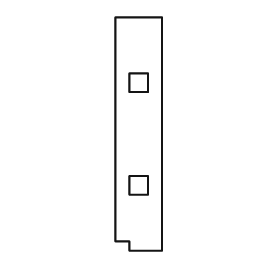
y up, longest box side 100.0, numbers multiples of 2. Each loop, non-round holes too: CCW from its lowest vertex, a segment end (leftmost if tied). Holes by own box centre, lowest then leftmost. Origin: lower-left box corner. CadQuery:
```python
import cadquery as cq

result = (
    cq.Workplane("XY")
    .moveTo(6.0, 0.0)
    .lineTo(20.0, 0.0)
    .lineTo(20.0, 100.0)
    .lineTo(0.0, 100.0)
    .lineTo(0.0, 4.0)
    .lineTo(6.0, 4.0)
    .close()
    .moveTo(6.0, 24.0)
    .lineTo(14.0, 24.0)
    .lineTo(14.0, 32.0)
    .lineTo(6.0, 32.0)
    .close()
    .moveTo(6.0, 68.0)
    .lineTo(14.0, 68.0)
    .lineTo(14.0, 76.0)
    .lineTo(6.0, 76.0)
    .close()
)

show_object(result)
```